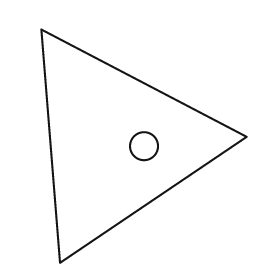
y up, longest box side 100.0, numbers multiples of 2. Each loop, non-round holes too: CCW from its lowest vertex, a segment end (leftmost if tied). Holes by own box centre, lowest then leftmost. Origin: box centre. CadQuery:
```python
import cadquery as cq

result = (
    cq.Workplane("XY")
    .moveTo(-36.0, -50.0)
    .lineTo(44.0, 4.0)
    .lineTo(-44.0, 50.0)
    .close()
    .moveTo(0.0, 0.0)
    .circle(6.0)
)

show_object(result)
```